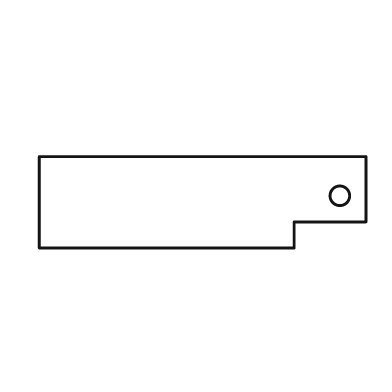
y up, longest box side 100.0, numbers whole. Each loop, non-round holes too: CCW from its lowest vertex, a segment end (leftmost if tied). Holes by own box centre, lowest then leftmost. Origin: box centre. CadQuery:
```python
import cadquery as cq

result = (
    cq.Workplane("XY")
    .moveTo(-50.0, -14.0)
    .lineTo(28.0, -14.0)
    .lineTo(28.0, -6.0)
    .lineTo(50.0, -6.0)
    .lineTo(50.0, 14.0)
    .lineTo(-50.0, 14.0)
    .close()
    .moveTo(42.0, 2.0)
    .circle(3.0)
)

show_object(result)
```